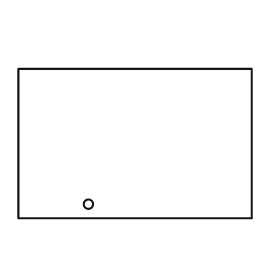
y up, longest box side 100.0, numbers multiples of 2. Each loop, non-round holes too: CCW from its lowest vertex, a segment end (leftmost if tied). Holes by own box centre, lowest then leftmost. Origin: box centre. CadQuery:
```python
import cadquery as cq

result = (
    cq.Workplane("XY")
    .moveTo(-50.0, -32.0)
    .lineTo(50.0, -32.0)
    .lineTo(50.0, 32.0)
    .lineTo(-50.0, 32.0)
    .close()
    .moveTo(-20.0, -26.0)
    .circle(2.0)
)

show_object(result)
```